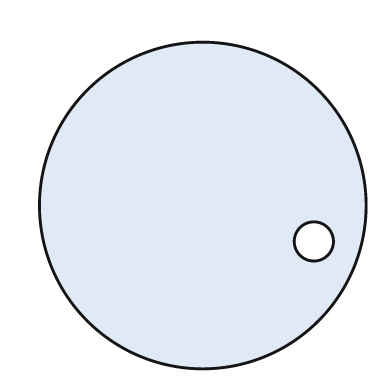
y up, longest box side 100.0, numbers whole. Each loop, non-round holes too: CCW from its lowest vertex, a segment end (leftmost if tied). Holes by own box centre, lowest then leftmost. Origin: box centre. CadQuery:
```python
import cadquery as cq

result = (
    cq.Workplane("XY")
    .moveTo(0.0, 0.0)
    .circle(50.0)
    .moveTo(34.0, -11.0)
    .circle(6.0)
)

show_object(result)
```